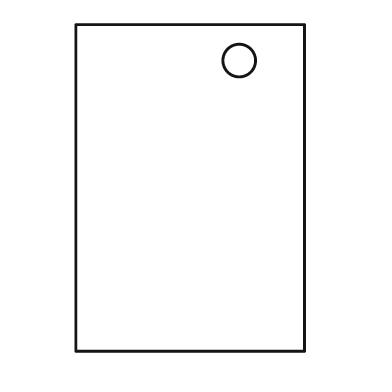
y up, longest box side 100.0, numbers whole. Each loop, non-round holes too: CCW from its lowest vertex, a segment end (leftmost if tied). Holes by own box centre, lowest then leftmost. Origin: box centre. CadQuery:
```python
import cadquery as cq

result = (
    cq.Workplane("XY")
    .moveTo(-35.0, -50.0)
    .lineTo(35.0, -50.0)
    .lineTo(35.0, 50.0)
    .lineTo(-35.0, 50.0)
    .close()
    .moveTo(15.0, 39.0)
    .circle(5.0)
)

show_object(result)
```